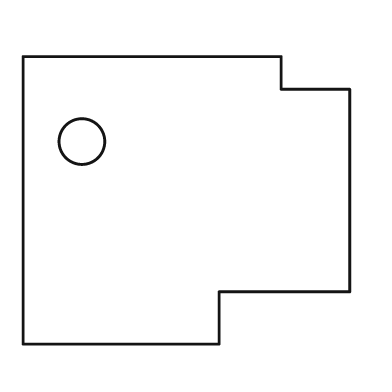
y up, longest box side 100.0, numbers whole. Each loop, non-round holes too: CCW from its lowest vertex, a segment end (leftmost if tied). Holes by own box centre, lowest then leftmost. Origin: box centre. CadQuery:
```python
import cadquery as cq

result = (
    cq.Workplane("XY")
    .moveTo(-50.0, -44.0)
    .lineTo(10.0, -44.0)
    .lineTo(10.0, -28.0)
    .lineTo(50.0, -28.0)
    .lineTo(50.0, 34.0)
    .lineTo(29.0, 34.0)
    .lineTo(29.0, 44.0)
    .lineTo(-50.0, 44.0)
    .close()
    .moveTo(-32.0, 18.0)
    .circle(7.0)
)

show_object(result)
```